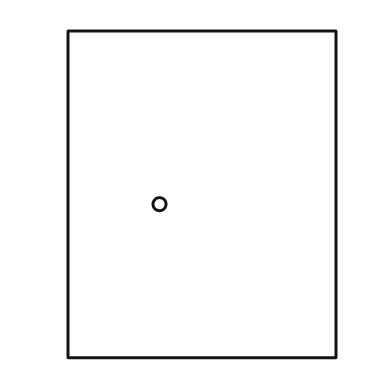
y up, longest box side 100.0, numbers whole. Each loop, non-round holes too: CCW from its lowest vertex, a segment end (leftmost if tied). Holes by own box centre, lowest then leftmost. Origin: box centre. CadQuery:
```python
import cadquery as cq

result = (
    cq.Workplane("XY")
    .moveTo(-41.0, -50.0)
    .lineTo(41.0, -50.0)
    .lineTo(41.0, 50.0)
    .lineTo(-41.0, 50.0)
    .close()
    .moveTo(-13.0, -3.0)
    .circle(2.0)
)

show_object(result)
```